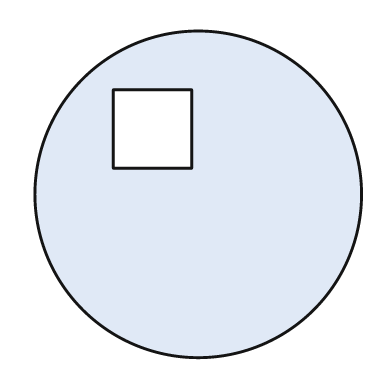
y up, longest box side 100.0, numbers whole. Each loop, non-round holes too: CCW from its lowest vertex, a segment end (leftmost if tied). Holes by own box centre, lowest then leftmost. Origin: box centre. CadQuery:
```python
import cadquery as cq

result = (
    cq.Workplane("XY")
    .moveTo(0.0, 0.0)
    .circle(50.0)
    .moveTo(-26.0, 8.0)
    .lineTo(-2.0, 8.0)
    .lineTo(-2.0, 32.0)
    .lineTo(-26.0, 32.0)
    .close()
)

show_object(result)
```